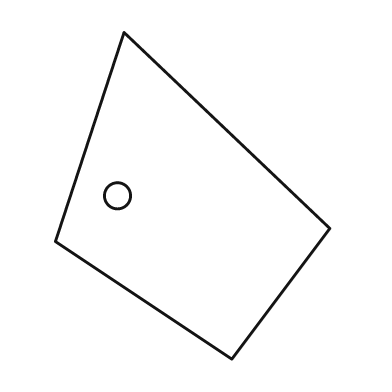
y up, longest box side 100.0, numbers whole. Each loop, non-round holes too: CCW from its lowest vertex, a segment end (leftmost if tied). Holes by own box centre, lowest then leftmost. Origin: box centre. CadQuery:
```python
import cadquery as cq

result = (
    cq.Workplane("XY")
    .moveTo(12.0, -50.0)
    .lineTo(42.0, -10.0)
    .lineTo(-21.0, 50.0)
    .lineTo(-42.0, -14.0)
    .close()
    .moveTo(-23.0, 0.0)
    .circle(4.0)
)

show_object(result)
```